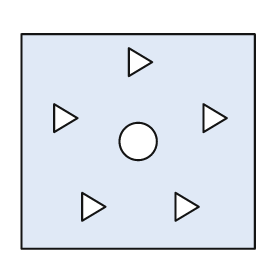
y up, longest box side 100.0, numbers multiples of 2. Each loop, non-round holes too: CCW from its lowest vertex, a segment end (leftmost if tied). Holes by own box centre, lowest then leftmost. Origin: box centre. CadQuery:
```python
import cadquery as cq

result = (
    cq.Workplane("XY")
    .moveTo(-50.0, -46.0)
    .lineTo(50.0, -46.0)
    .lineTo(50.0, 46.0)
    .lineTo(-50.0, 46.0)
    .close()
    .moveTo(-24.0, -34.0)
    .lineTo(-14.0, -28.0)
    .lineTo(-24.0, -22.0)
    .close()
    .moveTo(16.0, -34.0)
    .lineTo(26.0, -28.0)
    .lineTo(16.0, -22.0)
    .close()
    .moveTo(0.0, 0.0)
    .circle(8.0)
    .moveTo(-36.0, 4.0)
    .lineTo(-26.0, 10.0)
    .lineTo(-36.0, 16.0)
    .close()
    .moveTo(28.0, 4.0)
    .lineTo(38.0, 10.0)
    .lineTo(28.0, 16.0)
    .close()
    .moveTo(-4.0, 28.0)
    .lineTo(6.0, 34.0)
    .lineTo(-4.0, 40.0)
    .close()
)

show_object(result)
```